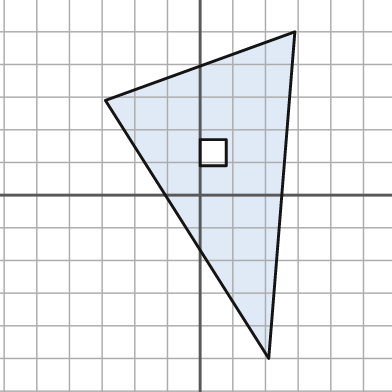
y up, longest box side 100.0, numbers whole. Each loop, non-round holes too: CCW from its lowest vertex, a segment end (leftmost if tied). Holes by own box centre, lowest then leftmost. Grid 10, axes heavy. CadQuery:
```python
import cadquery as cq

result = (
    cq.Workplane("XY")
    .moveTo(21.0, -50.0)
    .lineTo(29.0, 50.0)
    .lineTo(-29.0, 29.0)
    .close()
    .moveTo(0.0, 9.0)
    .lineTo(8.0, 9.0)
    .lineTo(8.0, 17.0)
    .lineTo(0.0, 17.0)
    .close()
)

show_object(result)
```